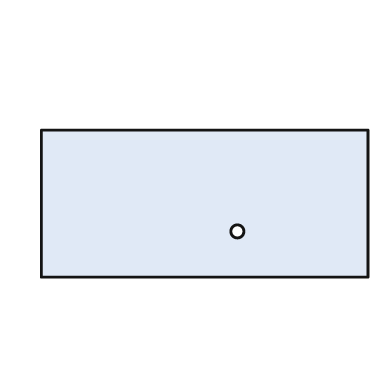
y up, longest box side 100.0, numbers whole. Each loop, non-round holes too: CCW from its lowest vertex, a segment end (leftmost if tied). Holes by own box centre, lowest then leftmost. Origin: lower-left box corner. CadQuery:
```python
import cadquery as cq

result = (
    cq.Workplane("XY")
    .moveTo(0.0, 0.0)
    .lineTo(100.0, 0.0)
    .lineTo(100.0, 45.0)
    .lineTo(0.0, 45.0)
    .close()
    .moveTo(60.0, 14.0)
    .circle(2.0)
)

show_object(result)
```